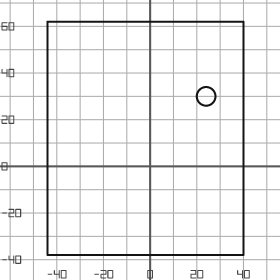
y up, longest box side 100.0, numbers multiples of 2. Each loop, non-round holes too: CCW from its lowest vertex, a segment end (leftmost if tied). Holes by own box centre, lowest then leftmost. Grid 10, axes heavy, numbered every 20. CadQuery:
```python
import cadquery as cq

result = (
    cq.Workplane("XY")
    .moveTo(-44.0, -38.0)
    .lineTo(40.0, -38.0)
    .lineTo(40.0, 62.0)
    .lineTo(-44.0, 62.0)
    .close()
    .moveTo(24.0, 30.0)
    .circle(4.0)
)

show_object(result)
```